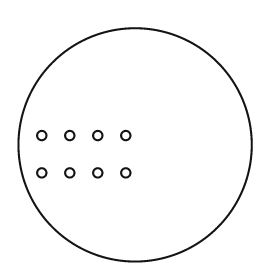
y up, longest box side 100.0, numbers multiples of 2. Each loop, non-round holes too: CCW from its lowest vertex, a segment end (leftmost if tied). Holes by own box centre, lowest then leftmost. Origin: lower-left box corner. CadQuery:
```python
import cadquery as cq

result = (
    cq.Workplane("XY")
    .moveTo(50.0, 50.0)
    .circle(50.0)
    .moveTo(10.0, 38.0)
    .circle(2.0)
    .moveTo(22.0, 38.0)
    .circle(2.0)
    .moveTo(34.0, 38.0)
    .circle(2.0)
    .moveTo(46.0, 38.0)
    .circle(2.0)
    .moveTo(10.0, 54.0)
    .circle(2.0)
    .moveTo(22.0, 54.0)
    .circle(2.0)
    .moveTo(34.0, 54.0)
    .circle(2.0)
    .moveTo(46.0, 54.0)
    .circle(2.0)
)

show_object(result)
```